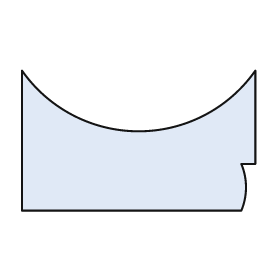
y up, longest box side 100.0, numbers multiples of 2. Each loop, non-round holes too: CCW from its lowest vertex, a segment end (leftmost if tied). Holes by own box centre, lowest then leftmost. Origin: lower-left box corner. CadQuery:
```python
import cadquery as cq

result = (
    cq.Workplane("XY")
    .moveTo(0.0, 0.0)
    .lineTo(94.0, 0.0)
    .threePointArc((96.0, 10.0), (94.0, 20.0))
    .lineTo(100.0, 20.0)
    .lineTo(100.0, 60.0)
    .threePointArc((50.0, 34.0), (0.0, 60.0))
    .close()
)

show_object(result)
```